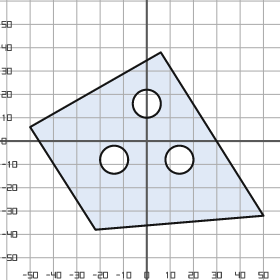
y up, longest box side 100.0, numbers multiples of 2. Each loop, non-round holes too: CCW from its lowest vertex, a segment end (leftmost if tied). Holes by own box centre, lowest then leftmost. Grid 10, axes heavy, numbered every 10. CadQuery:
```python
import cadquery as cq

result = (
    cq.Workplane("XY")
    .moveTo(-22.0, -38.0)
    .lineTo(50.0, -32.0)
    .lineTo(6.0, 38.0)
    .lineTo(-50.0, 6.0)
    .close()
    .moveTo(-14.0, -8.0)
    .circle(6.0)
    .moveTo(14.0, -8.0)
    .circle(6.0)
    .moveTo(0.0, 16.0)
    .circle(6.0)
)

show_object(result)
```